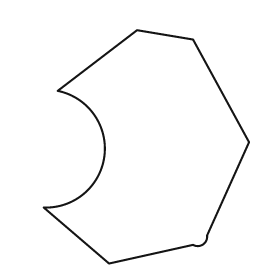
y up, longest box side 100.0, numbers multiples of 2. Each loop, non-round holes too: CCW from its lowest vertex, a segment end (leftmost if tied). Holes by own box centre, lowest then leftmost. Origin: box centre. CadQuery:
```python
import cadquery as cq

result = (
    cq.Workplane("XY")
    .moveTo(-16.0, -50.0)
    .lineTo(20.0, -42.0)
    .threePointArc((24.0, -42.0), (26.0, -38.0))
    .lineTo(44.0, 2.0)
    .lineTo(20.0, 46.0)
    .lineTo(-4.0, 50.0)
    .lineTo(-38.0, 24.0)
    .threePointArc((-18.0, -4.0), (-44.0, -26.0))
    .close()
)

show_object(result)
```